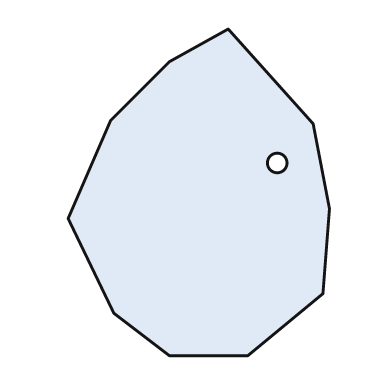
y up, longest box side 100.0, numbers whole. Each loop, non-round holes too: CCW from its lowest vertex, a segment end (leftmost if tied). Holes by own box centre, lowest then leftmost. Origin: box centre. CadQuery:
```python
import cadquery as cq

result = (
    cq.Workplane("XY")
    .moveTo(-9.0, -50.0)
    .lineTo(15.0, -50.0)
    .lineTo(38.0, -31.0)
    .lineTo(40.0, -5.0)
    .lineTo(35.0, 21.0)
    .lineTo(9.0, 50.0)
    .lineTo(-9.0, 40.0)
    .lineTo(-27.0, 22.0)
    .lineTo(-40.0, -8.0)
    .lineTo(-26.0, -37.0)
    .close()
    .moveTo(24.0, 9.0)
    .circle(3.0)
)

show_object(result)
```